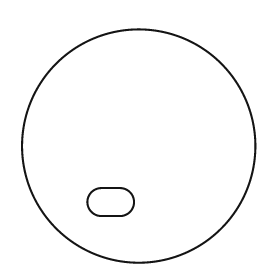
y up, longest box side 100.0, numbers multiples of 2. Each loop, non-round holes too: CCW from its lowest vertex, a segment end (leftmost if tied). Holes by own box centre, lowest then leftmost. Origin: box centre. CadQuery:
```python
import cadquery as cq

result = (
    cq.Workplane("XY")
    .moveTo(0.0, 0.0)
    .circle(50.0)
    .moveTo(-16.0, -30.0)
    .lineTo(-8.0, -30.0)
    .threePointArc((-2.0, -24.0), (-8.0, -18.0))
    .lineTo(-16.0, -18.0)
    .threePointArc((-22.0, -24.0), (-16.0, -30.0))
    .close()
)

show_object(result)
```